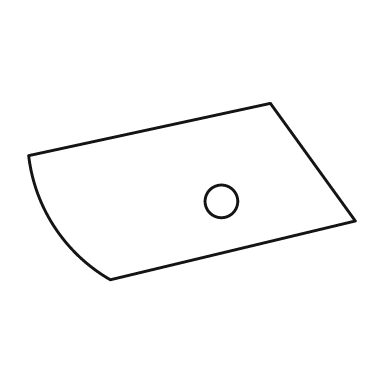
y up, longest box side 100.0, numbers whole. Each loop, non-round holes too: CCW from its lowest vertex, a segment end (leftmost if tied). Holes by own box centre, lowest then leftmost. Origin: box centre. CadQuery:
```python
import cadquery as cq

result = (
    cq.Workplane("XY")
    .moveTo(-25.0, -27.0)
    .lineTo(50.0, -9.0)
    .lineTo(24.0, 27.0)
    .lineTo(-50.0, 11.0)
    .threePointArc((-42.0, -11.0), (-25.0, -27.0))
    .close()
    .moveTo(9.0, -3.0)
    .circle(5.0)
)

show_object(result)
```